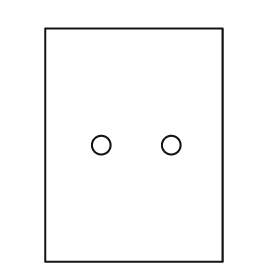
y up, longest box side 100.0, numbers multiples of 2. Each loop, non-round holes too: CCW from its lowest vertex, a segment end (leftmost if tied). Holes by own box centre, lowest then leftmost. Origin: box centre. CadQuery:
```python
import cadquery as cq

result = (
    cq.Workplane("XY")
    .moveTo(-38.0, -50.0)
    .lineTo(38.0, -50.0)
    .lineTo(38.0, 50.0)
    .lineTo(-38.0, 50.0)
    .close()
    .moveTo(-14.0, 0.0)
    .circle(4.0)
    .moveTo(16.0, 0.0)
    .circle(4.0)
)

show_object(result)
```